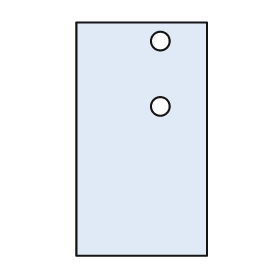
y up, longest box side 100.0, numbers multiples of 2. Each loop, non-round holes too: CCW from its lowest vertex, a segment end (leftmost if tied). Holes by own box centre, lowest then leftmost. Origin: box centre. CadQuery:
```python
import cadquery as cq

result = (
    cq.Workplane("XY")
    .moveTo(-28.0, -50.0)
    .lineTo(28.0, -50.0)
    .lineTo(28.0, 50.0)
    .lineTo(-28.0, 50.0)
    .close()
    .moveTo(8.0, 14.0)
    .circle(4.0)
    .moveTo(8.0, 42.0)
    .circle(4.0)
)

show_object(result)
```